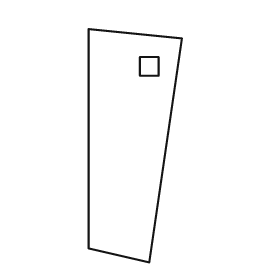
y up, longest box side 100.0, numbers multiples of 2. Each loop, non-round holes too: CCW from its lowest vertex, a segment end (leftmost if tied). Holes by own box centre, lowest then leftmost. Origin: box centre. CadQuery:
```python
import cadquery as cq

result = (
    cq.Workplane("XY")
    .moveTo(6.0, -50.0)
    .lineTo(20.0, 46.0)
    .lineTo(-20.0, 50.0)
    .lineTo(-20.0, -44.0)
    .close()
    .moveTo(2.0, 30.0)
    .lineTo(10.0, 30.0)
    .lineTo(10.0, 38.0)
    .lineTo(2.0, 38.0)
    .close()
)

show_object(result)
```